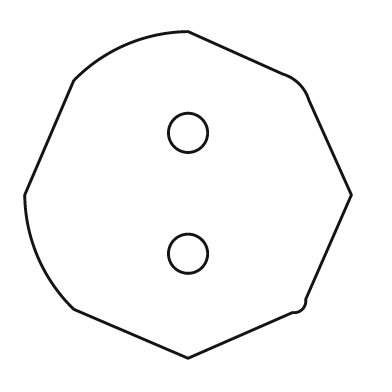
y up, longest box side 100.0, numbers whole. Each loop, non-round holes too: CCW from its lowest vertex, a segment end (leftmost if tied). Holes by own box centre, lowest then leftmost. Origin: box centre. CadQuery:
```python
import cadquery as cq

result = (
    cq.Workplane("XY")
    .moveTo(0.0, -50.0)
    .lineTo(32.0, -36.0)
    .threePointArc((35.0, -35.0), (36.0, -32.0))
    .lineTo(50.0, 0.0)
    .lineTo(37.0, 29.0)
    .threePointArc((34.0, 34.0), (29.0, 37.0))
    .lineTo(0.0, 50.0)
    .threePointArc((-19.0, 46.0), (-35.0, 35.0))
    .lineTo(-50.0, 0.0)
    .threePointArc((-46.0, -19.0), (-35.0, -35.0))
    .close()
    .moveTo(0.0, -18.0)
    .circle(6.0)
    .moveTo(0.0, 19.0)
    .circle(6.0)
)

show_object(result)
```